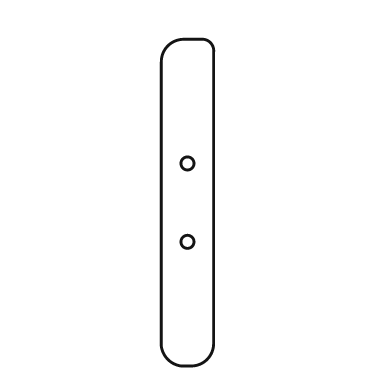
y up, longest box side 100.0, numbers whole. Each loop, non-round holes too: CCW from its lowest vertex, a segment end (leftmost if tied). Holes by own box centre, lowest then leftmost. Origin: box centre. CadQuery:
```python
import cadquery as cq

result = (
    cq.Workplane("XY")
    .moveTo(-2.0, -50.0)
    .lineTo(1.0, -50.0)
    .threePointArc((6.0, -48.0), (8.0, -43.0))
    .lineTo(8.0, 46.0)
    .threePointArc((7.0, 49.0), (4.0, 50.0))
    .lineTo(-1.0, 50.0)
    .threePointArc((-6.0, 48.0), (-8.0, 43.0))
    .lineTo(-8.0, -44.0)
    .threePointArc((-6.0, -48.0), (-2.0, -50.0))
    .close()
    .moveTo(0.0, -12.0)
    .circle(2.0)
    .moveTo(0.0, 12.0)
    .circle(2.0)
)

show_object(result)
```